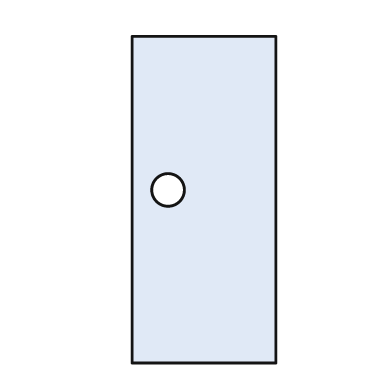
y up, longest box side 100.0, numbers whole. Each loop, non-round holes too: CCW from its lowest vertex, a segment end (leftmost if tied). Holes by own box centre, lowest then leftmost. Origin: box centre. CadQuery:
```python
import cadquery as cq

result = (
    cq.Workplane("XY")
    .moveTo(-22.0, -50.0)
    .lineTo(22.0, -50.0)
    .lineTo(22.0, 50.0)
    .lineTo(-22.0, 50.0)
    .close()
    .moveTo(-11.0, 3.0)
    .circle(5.0)
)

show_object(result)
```